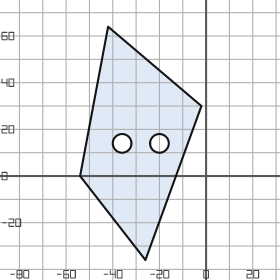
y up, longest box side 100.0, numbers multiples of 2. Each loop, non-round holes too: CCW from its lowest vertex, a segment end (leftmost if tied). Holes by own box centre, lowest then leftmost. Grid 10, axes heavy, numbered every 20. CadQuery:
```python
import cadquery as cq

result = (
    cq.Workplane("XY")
    .moveTo(-26.0, -36.0)
    .lineTo(-2.0, 30.0)
    .lineTo(-42.0, 64.0)
    .lineTo(-54.0, 0.0)
    .close()
    .moveTo(-36.0, 14.0)
    .circle(4.0)
    .moveTo(-20.0, 14.0)
    .circle(4.0)
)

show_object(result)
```